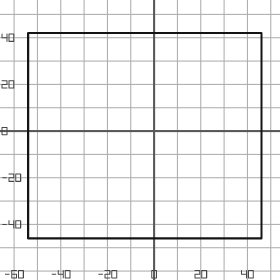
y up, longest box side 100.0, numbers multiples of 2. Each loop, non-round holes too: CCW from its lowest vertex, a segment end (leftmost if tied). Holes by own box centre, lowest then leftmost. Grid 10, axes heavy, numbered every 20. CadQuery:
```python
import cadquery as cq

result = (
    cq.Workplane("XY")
    .moveTo(-54.0, -46.0)
    .lineTo(46.0, -46.0)
    .lineTo(46.0, 42.0)
    .lineTo(-54.0, 42.0)
    .close()
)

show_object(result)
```